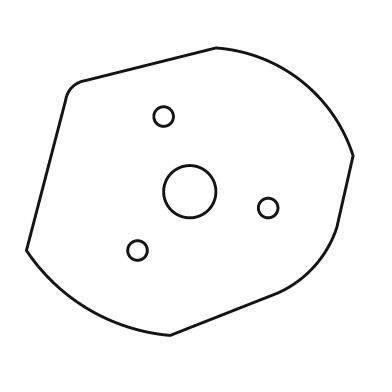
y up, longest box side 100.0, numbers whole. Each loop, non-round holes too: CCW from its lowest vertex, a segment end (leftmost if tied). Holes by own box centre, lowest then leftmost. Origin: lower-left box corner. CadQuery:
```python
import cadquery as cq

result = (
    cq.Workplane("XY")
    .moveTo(44.0, 0.0)
    .lineTo(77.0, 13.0)
    .threePointArc((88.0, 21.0), (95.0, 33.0))
    .lineTo(100.0, 55.0)
    .threePointArc((84.0, 78.0), (58.0, 88.0))
    .lineTo(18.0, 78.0)
    .threePointArc((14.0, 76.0), (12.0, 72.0))
    .lineTo(0.0, 26.0)
    .threePointArc((19.0, 8.0), (44.0, 0.0))
    .close()
    .moveTo(34.0, 26.0)
    .circle(3.0)
    .moveTo(74.0, 39.0)
    .circle(3.0)
    .moveTo(50.0, 44.0)
    .circle(8.0)
    .moveTo(42.0, 67.0)
    .circle(3.0)
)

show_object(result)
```